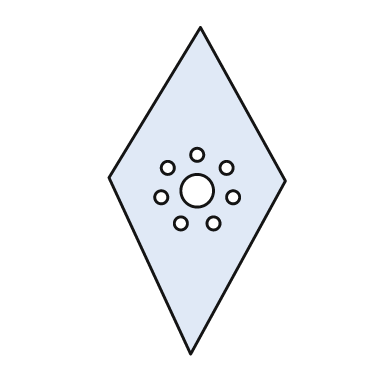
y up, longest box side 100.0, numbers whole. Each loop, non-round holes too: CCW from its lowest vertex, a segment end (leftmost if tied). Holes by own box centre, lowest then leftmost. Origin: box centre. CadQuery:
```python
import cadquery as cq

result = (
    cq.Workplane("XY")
    .moveTo(-2.0, -50.0)
    .lineTo(27.0, 3.0)
    .lineTo(1.0, 50.0)
    .lineTo(-27.0, 4.0)
    .close()
    .moveTo(-5.0, -10.0)
    .circle(2.0)
    .moveTo(5.0, -10.0)
    .circle(2.0)
    .moveTo(-11.0, -2.0)
    .circle(2.0)
    .moveTo(11.0, -2.0)
    .circle(2.0)
    .moveTo(0.0, 0.0)
    .circle(5.0)
    .moveTo(-9.0, 7.0)
    .circle(2.0)
    .moveTo(9.0, 7.0)
    .circle(2.0)
    .moveTo(0.0, 11.0)
    .circle(2.0)
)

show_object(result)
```